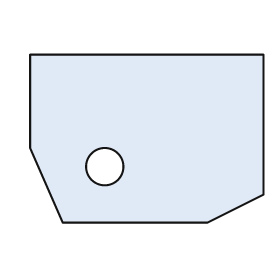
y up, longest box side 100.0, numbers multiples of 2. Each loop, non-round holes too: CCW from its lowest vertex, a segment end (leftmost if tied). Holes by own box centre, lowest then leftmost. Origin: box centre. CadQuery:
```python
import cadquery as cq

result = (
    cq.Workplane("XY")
    .moveTo(-36.0, -36.0)
    .lineTo(26.0, -36.0)
    .lineTo(50.0, -24.0)
    .lineTo(50.0, 36.0)
    .lineTo(-50.0, 36.0)
    .lineTo(-50.0, -4.0)
    .close()
    .moveTo(-18.0, -12.0)
    .circle(8.0)
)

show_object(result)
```